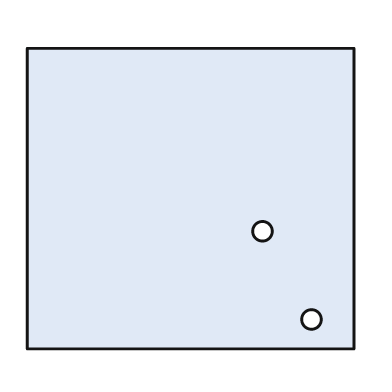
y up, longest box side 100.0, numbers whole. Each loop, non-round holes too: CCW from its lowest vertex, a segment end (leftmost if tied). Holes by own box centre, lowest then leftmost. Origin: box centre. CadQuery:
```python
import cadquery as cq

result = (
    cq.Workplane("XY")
    .moveTo(-50.0, -46.0)
    .lineTo(50.0, -46.0)
    .lineTo(50.0, 46.0)
    .lineTo(-50.0, 46.0)
    .close()
    .moveTo(37.0, -37.0)
    .circle(3.0)
    .moveTo(22.0, -10.0)
    .circle(3.0)
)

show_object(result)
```